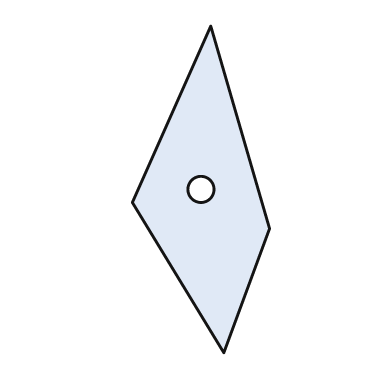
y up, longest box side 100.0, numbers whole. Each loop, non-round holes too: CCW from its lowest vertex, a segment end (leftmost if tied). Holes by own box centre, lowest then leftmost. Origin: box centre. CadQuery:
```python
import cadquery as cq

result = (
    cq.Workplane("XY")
    .moveTo(7.0, -50.0)
    .lineTo(21.0, -12.0)
    .lineTo(3.0, 50.0)
    .lineTo(-21.0, -4.0)
    .close()
    .moveTo(0.0, 0.0)
    .circle(4.0)
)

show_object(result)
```